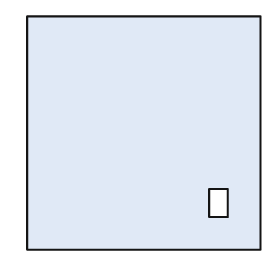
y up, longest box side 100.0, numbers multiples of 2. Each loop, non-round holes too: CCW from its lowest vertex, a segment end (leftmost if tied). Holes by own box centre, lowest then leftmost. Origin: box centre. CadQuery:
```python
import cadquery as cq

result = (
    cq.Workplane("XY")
    .moveTo(-50.0, -50.0)
    .lineTo(50.0, -50.0)
    .lineTo(50.0, 50.0)
    .lineTo(-50.0, 50.0)
    .close()
    .moveTo(28.0, -36.0)
    .lineTo(36.0, -36.0)
    .lineTo(36.0, -24.0)
    .lineTo(28.0, -24.0)
    .close()
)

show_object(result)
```